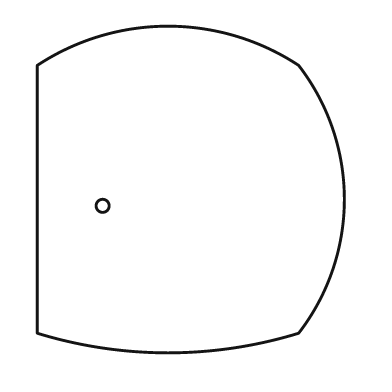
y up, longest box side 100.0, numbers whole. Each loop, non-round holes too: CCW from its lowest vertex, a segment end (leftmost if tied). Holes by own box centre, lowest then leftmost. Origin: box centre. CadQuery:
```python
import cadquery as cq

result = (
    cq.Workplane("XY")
    .moveTo(-47.0, -44.0)
    .threePointArc((-7.0, -50.0), (33.0, -44.0))
    .threePointArc((47.0, -3.0), (33.0, 38.0))
    .threePointArc((-7.0, 50.0), (-47.0, 38.0))
    .close()
    .moveTo(-27.0, -5.0)
    .circle(2.0)
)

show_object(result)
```